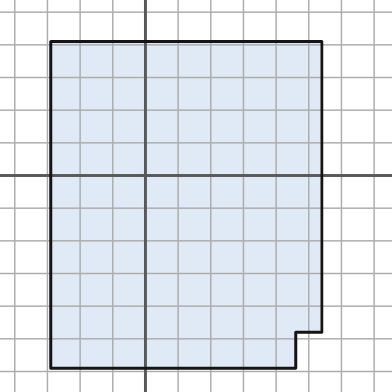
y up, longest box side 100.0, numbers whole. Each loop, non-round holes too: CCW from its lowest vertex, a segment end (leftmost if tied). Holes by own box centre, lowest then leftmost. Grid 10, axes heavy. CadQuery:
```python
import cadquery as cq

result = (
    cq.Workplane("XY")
    .moveTo(-29.0, -59.0)
    .lineTo(46.0, -59.0)
    .lineTo(46.0, -48.0)
    .lineTo(54.0, -48.0)
    .lineTo(54.0, 41.0)
    .lineTo(-29.0, 41.0)
    .close()
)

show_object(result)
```